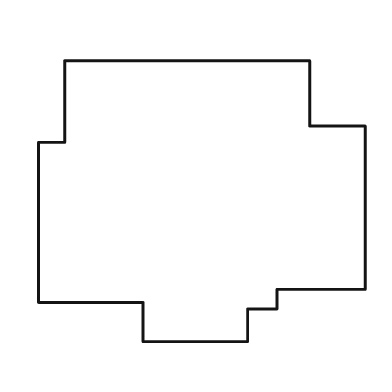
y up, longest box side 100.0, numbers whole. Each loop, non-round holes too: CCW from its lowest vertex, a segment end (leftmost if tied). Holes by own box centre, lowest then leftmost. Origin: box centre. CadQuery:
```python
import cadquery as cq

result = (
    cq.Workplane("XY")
    .moveTo(-18.0, -43.0)
    .lineTo(14.0, -43.0)
    .lineTo(14.0, -33.0)
    .lineTo(23.0, -33.0)
    .lineTo(23.0, -27.0)
    .lineTo(50.0, -27.0)
    .lineTo(50.0, 23.0)
    .lineTo(33.0, 23.0)
    .lineTo(33.0, 43.0)
    .lineTo(-42.0, 43.0)
    .lineTo(-42.0, 18.0)
    .lineTo(-50.0, 18.0)
    .lineTo(-50.0, -31.0)
    .lineTo(-18.0, -31.0)
    .close()
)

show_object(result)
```